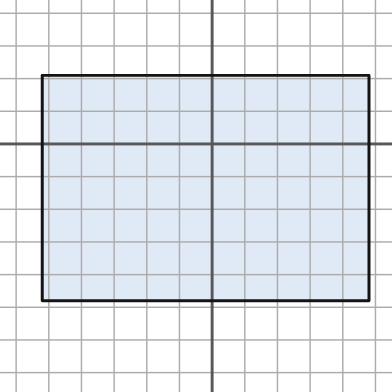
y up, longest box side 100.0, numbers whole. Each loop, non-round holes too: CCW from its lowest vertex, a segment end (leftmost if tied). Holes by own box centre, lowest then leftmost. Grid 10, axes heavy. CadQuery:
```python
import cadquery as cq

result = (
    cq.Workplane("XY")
    .moveTo(-52.0, -48.0)
    .lineTo(48.0, -48.0)
    .lineTo(48.0, 21.0)
    .lineTo(-52.0, 21.0)
    .close()
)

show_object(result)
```